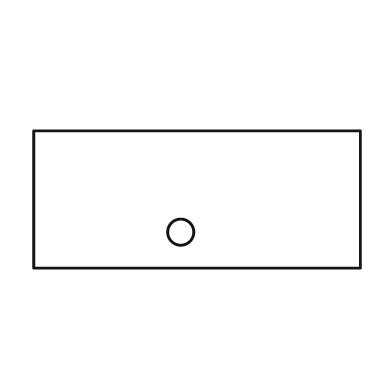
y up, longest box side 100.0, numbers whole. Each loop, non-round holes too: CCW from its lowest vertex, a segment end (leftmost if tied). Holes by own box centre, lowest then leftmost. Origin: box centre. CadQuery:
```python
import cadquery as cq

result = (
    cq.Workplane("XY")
    .moveTo(-50.0, -21.0)
    .lineTo(50.0, -21.0)
    .lineTo(50.0, 21.0)
    .lineTo(-50.0, 21.0)
    .close()
    .moveTo(-5.0, -10.0)
    .circle(4.0)
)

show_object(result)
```